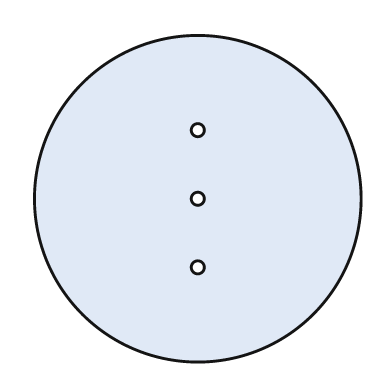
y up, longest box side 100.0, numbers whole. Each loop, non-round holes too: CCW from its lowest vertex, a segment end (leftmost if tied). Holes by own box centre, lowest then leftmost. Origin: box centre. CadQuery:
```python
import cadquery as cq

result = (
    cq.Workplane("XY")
    .moveTo(0.0, 0.0)
    .circle(50.0)
    .moveTo(0.0, -21.0)
    .circle(2.0)
    .moveTo(0.0, 0.0)
    .circle(2.0)
    .moveTo(0.0, 21.0)
    .circle(2.0)
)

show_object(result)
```